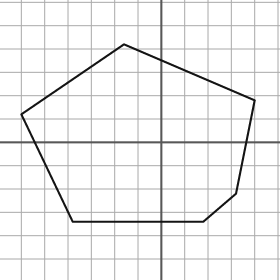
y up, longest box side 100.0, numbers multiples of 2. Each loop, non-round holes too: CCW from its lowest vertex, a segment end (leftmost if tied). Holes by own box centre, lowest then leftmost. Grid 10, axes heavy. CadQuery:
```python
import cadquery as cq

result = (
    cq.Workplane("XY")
    .moveTo(-38.0, -34.0)
    .lineTo(18.0, -34.0)
    .lineTo(32.0, -22.0)
    .lineTo(40.0, 18.0)
    .lineTo(-16.0, 42.0)
    .lineTo(-60.0, 12.0)
    .close()
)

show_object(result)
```